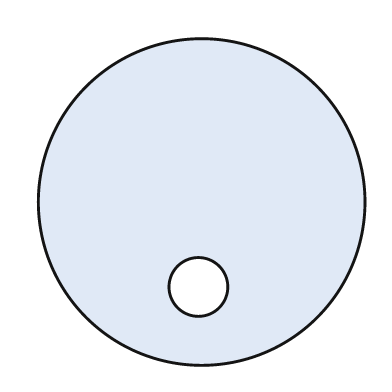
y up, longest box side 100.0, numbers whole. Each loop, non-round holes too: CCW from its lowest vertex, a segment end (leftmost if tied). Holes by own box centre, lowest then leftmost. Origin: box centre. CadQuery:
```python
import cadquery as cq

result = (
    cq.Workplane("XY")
    .moveTo(0.0, 0.0)
    .circle(50.0)
    .moveTo(-1.0, -26.0)
    .circle(9.0)
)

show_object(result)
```